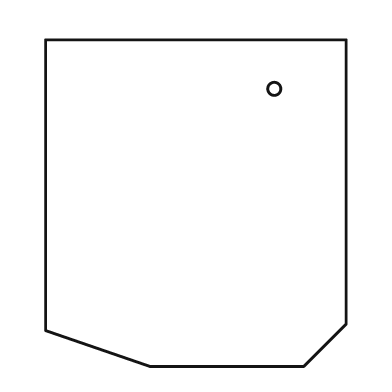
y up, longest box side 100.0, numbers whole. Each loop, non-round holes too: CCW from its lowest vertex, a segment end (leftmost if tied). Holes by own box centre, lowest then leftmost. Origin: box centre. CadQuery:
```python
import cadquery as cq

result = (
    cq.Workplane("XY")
    .moveTo(-14.0, -50.0)
    .lineTo(33.0, -50.0)
    .lineTo(46.0, -37.0)
    .lineTo(46.0, 50.0)
    .lineTo(-46.0, 50.0)
    .lineTo(-46.0, -39.0)
    .close()
    .moveTo(24.0, 35.0)
    .circle(2.0)
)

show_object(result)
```